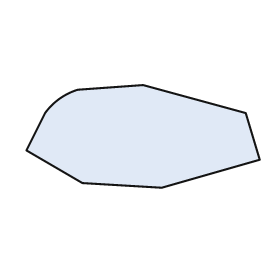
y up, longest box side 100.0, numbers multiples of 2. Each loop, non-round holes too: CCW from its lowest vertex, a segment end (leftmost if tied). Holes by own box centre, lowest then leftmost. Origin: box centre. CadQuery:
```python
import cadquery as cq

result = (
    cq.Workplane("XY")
    .moveTo(8.0, -22.0)
    .lineTo(50.0, -10.0)
    .lineTo(44.0, 10.0)
    .lineTo(0.0, 22.0)
    .lineTo(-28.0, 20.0)
    .threePointArc((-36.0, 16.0), (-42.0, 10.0))
    .lineTo(-50.0, -6.0)
    .lineTo(-26.0, -20.0)
    .close()
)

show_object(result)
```